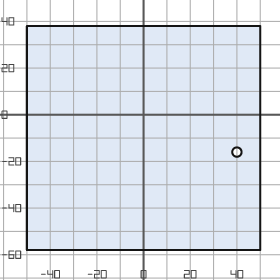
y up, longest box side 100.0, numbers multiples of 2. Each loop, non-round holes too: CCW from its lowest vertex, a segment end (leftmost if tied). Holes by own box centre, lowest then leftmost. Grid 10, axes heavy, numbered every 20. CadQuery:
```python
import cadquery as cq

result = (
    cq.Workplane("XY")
    .moveTo(-50.0, -58.0)
    .lineTo(50.0, -58.0)
    .lineTo(50.0, 38.0)
    .lineTo(-50.0, 38.0)
    .close()
    .moveTo(40.0, -16.0)
    .circle(2.0)
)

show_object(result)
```